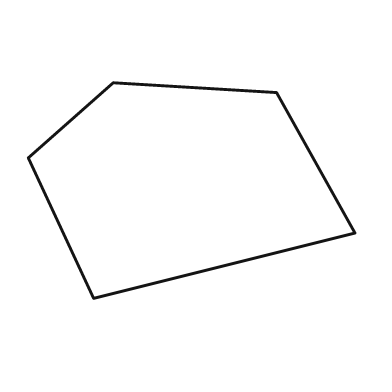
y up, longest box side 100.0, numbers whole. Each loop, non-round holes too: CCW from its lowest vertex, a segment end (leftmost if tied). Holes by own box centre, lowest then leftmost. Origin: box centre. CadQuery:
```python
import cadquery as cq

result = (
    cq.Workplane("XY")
    .moveTo(-30.0, -33.0)
    .lineTo(50.0, -13.0)
    .lineTo(26.0, 30.0)
    .lineTo(-24.0, 33.0)
    .lineTo(-50.0, 10.0)
    .close()
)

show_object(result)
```